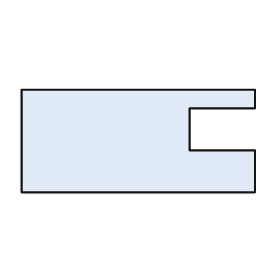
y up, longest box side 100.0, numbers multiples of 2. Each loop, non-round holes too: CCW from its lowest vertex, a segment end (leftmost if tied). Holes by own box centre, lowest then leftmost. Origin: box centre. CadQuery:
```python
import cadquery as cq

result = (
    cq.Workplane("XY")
    .moveTo(-50.0, -22.0)
    .lineTo(50.0, -22.0)
    .lineTo(50.0, -4.0)
    .lineTo(22.0, -4.0)
    .lineTo(22.0, 14.0)
    .lineTo(50.0, 14.0)
    .lineTo(50.0, 22.0)
    .lineTo(-50.0, 22.0)
    .close()
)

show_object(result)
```